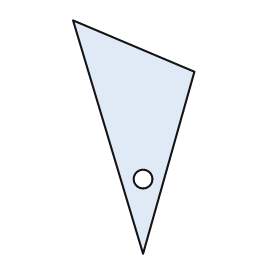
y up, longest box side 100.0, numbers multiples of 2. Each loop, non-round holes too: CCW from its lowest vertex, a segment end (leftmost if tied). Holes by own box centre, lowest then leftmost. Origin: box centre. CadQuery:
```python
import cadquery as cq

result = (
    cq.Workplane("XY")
    .moveTo(4.0, -50.0)
    .lineTo(26.0, 28.0)
    .lineTo(-26.0, 50.0)
    .close()
    .moveTo(4.0, -18.0)
    .circle(4.0)
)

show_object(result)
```